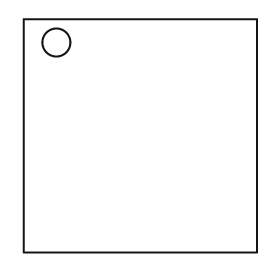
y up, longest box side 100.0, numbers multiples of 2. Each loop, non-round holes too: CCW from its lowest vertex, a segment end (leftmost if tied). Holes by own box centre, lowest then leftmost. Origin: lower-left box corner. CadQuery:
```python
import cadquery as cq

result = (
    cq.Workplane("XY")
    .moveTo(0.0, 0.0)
    .lineTo(100.0, 0.0)
    .lineTo(100.0, 100.0)
    .lineTo(0.0, 100.0)
    .close()
    .moveTo(14.0, 90.0)
    .circle(6.0)
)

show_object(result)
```